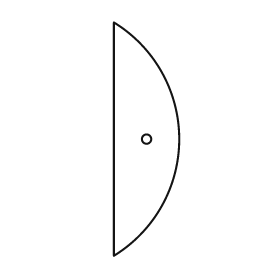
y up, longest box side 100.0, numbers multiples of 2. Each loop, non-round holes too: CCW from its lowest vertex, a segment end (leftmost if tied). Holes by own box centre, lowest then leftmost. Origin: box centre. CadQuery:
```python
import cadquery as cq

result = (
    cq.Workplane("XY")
    .moveTo(-14.0, -50.0)
    .threePointArc((14.0, 0.0), (-14.0, 50.0))
    .close()
    .moveTo(0.0, 0.0)
    .circle(2.0)
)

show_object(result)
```